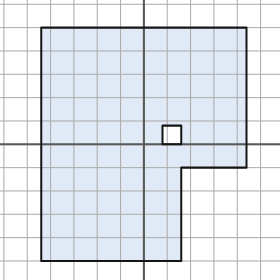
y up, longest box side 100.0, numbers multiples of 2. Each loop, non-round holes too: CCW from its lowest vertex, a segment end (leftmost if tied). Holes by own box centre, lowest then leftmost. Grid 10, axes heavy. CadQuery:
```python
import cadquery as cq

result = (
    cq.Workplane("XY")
    .moveTo(-44.0, -50.0)
    .lineTo(16.0, -50.0)
    .lineTo(16.0, -10.0)
    .lineTo(44.0, -10.0)
    .lineTo(44.0, 50.0)
    .lineTo(-44.0, 50.0)
    .close()
    .moveTo(8.0, 0.0)
    .lineTo(16.0, 0.0)
    .lineTo(16.0, 8.0)
    .lineTo(8.0, 8.0)
    .close()
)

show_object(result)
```